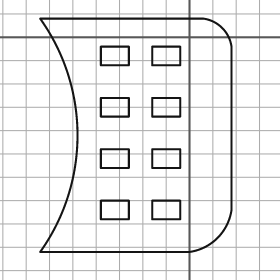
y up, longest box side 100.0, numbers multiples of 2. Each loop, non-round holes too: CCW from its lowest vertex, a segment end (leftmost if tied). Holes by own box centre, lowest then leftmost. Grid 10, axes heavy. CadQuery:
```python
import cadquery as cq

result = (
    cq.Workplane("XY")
    .moveTo(-64.0, -92.0)
    .lineTo(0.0, -92.0)
    .threePointArc((12.0, -86.0), (18.0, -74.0))
    .lineTo(18.0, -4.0)
    .threePointArc((14.0, 4.0), (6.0, 8.0))
    .lineTo(-64.0, 8.0)
    .threePointArc((-48.0, -42.0), (-64.0, -92.0))
    .close()
    .moveTo(-38.0, -78.0)
    .lineTo(-26.0, -78.0)
    .lineTo(-26.0, -70.0)
    .lineTo(-38.0, -70.0)
    .close()
    .moveTo(-16.0, -78.0)
    .lineTo(-4.0, -78.0)
    .lineTo(-4.0, -70.0)
    .lineTo(-16.0, -70.0)
    .close()
    .moveTo(-38.0, -56.0)
    .lineTo(-26.0, -56.0)
    .lineTo(-26.0, -48.0)
    .lineTo(-38.0, -48.0)
    .close()
    .moveTo(-16.0, -56.0)
    .lineTo(-4.0, -56.0)
    .lineTo(-4.0, -48.0)
    .lineTo(-16.0, -48.0)
    .close()
    .moveTo(-38.0, -34.0)
    .lineTo(-26.0, -34.0)
    .lineTo(-26.0, -26.0)
    .lineTo(-38.0, -26.0)
    .close()
    .moveTo(-16.0, -34.0)
    .lineTo(-4.0, -34.0)
    .lineTo(-4.0, -26.0)
    .lineTo(-16.0, -26.0)
    .close()
    .moveTo(-38.0, -12.0)
    .lineTo(-26.0, -12.0)
    .lineTo(-26.0, -4.0)
    .lineTo(-38.0, -4.0)
    .close()
    .moveTo(-16.0, -12.0)
    .lineTo(-4.0, -12.0)
    .lineTo(-4.0, -4.0)
    .lineTo(-16.0, -4.0)
    .close()
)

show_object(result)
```